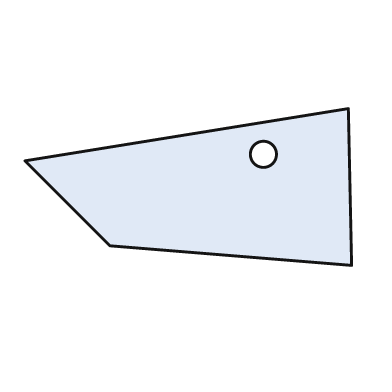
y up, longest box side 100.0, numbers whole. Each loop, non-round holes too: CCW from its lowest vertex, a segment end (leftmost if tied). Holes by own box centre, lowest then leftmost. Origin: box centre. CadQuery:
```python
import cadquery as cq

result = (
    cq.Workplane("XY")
    .moveTo(50.0, -24.0)
    .lineTo(49.0, 24.0)
    .lineTo(-50.0, 8.0)
    .lineTo(-24.0, -18.0)
    .close()
    .moveTo(23.0, 10.0)
    .circle(4.0)
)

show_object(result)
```